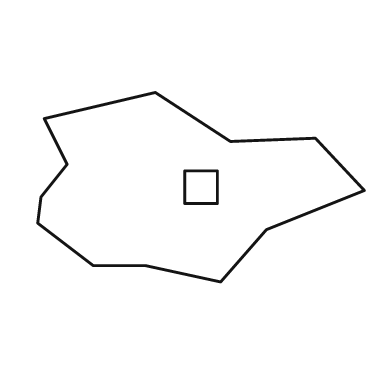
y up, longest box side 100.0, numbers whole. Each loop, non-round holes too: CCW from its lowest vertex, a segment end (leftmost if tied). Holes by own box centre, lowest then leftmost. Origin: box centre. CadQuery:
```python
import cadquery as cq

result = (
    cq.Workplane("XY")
    .moveTo(6.0, -29.0)
    .lineTo(20.0, -13.0)
    .lineTo(50.0, -1.0)
    .lineTo(35.0, 15.0)
    .lineTo(9.0, 14.0)
    .lineTo(-14.0, 29.0)
    .lineTo(-48.0, 21.0)
    .lineTo(-41.0, 7.0)
    .lineTo(-49.0, -3.0)
    .lineTo(-50.0, -11.0)
    .lineTo(-33.0, -24.0)
    .lineTo(-17.0, -24.0)
    .close()
    .moveTo(-5.0, -5.0)
    .lineTo(5.0, -5.0)
    .lineTo(5.0, 5.0)
    .lineTo(-5.0, 5.0)
    .close()
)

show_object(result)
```